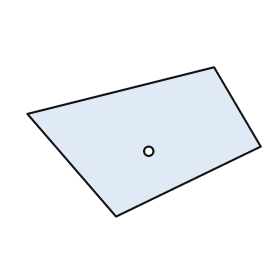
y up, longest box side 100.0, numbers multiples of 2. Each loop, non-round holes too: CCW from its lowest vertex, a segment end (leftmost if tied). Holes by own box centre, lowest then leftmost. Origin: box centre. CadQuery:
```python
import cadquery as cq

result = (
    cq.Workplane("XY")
    .moveTo(-12.0, -32.0)
    .lineTo(50.0, -2.0)
    .lineTo(30.0, 32.0)
    .lineTo(-50.0, 12.0)
    .close()
    .moveTo(2.0, -4.0)
    .circle(2.0)
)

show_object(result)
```